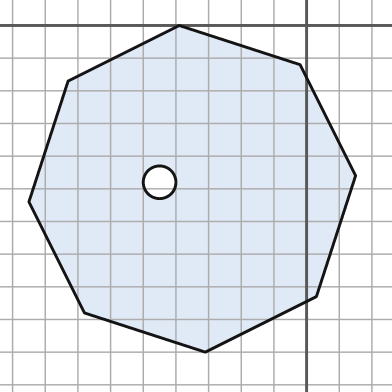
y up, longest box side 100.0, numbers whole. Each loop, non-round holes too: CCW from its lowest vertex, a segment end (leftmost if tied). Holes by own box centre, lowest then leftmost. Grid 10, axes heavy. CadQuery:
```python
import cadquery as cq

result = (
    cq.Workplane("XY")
    .moveTo(-31.0, -100.0)
    .lineTo(3.0, -83.0)
    .lineTo(15.0, -46.0)
    .lineTo(-2.0, -12.0)
    .lineTo(-39.0, 0.0)
    .lineTo(-73.0, -17.0)
    .lineTo(-85.0, -54.0)
    .lineTo(-68.0, -88.0)
    .close()
    .moveTo(-45.0, -48.0)
    .circle(5.0)
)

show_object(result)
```